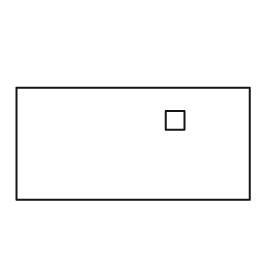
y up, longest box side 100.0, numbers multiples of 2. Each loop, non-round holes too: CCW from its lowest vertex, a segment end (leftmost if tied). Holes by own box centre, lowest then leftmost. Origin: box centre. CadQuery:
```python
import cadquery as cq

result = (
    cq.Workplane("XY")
    .moveTo(-50.0, -24.0)
    .lineTo(50.0, -24.0)
    .lineTo(50.0, 24.0)
    .lineTo(-50.0, 24.0)
    .close()
    .moveTo(14.0, 6.0)
    .lineTo(22.0, 6.0)
    .lineTo(22.0, 14.0)
    .lineTo(14.0, 14.0)
    .close()
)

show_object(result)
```